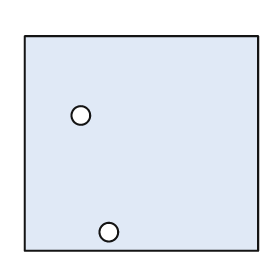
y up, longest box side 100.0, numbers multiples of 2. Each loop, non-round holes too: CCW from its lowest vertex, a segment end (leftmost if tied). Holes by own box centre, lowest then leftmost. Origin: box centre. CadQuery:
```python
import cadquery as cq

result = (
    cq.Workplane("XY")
    .moveTo(-50.0, -46.0)
    .lineTo(50.0, -46.0)
    .lineTo(50.0, 46.0)
    .lineTo(-50.0, 46.0)
    .close()
    .moveTo(-14.0, -38.0)
    .circle(4.0)
    .moveTo(-26.0, 12.0)
    .circle(4.0)
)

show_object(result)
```